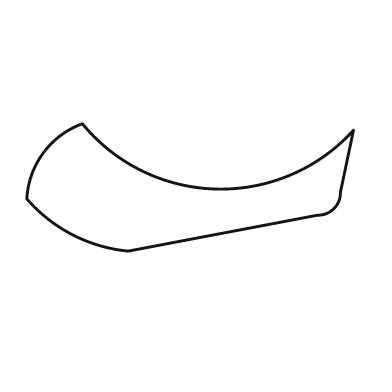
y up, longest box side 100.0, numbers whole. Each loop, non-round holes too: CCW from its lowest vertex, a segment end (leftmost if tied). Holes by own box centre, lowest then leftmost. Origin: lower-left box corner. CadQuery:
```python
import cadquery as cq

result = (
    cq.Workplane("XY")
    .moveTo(31.0, 0.0)
    .lineTo(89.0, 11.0)
    .threePointArc((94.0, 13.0), (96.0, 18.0))
    .lineTo(100.0, 37.0)
    .threePointArc((58.0, 19.0), (17.0, 39.0))
    .threePointArc((5.0, 30.0), (0.0, 16.0))
    .threePointArc((14.0, 5.0), (31.0, 0.0))
    .close()
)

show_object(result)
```